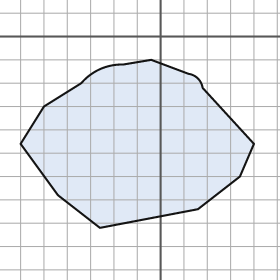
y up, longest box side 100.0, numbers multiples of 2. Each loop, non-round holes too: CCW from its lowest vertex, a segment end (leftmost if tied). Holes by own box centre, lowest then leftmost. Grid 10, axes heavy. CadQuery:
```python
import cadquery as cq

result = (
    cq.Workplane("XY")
    .moveTo(-26.0, -82.0)
    .lineTo(16.0, -74.0)
    .lineTo(34.0, -60.0)
    .lineTo(40.0, -46.0)
    .lineTo(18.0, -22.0)
    .threePointArc((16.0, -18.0), (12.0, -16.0))
    .lineTo(-4.0, -10.0)
    .lineTo(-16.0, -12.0)
    .threePointArc((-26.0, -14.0), (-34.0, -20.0))
    .lineTo(-50.0, -30.0)
    .lineTo(-60.0, -46.0)
    .lineTo(-44.0, -68.0)
    .close()
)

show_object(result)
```